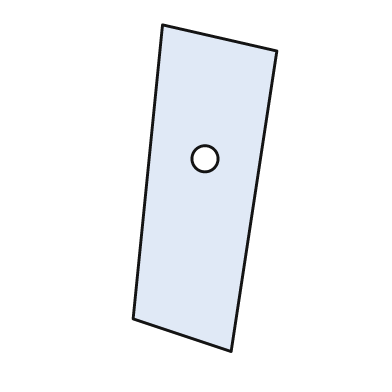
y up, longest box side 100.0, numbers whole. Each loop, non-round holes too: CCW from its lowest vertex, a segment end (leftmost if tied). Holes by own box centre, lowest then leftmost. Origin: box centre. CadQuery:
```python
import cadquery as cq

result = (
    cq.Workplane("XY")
    .moveTo(8.0, -50.0)
    .lineTo(22.0, 42.0)
    .lineTo(-13.0, 50.0)
    .lineTo(-22.0, -40.0)
    .close()
    .moveTo(0.0, 9.0)
    .circle(4.0)
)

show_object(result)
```